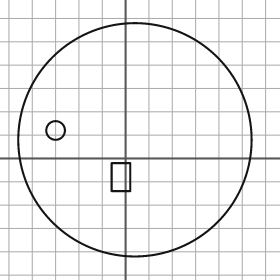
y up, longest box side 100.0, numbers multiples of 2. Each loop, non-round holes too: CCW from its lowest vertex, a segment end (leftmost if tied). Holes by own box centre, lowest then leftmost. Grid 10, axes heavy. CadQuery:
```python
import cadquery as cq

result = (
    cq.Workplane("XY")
    .moveTo(4.0, 8.0)
    .circle(50.0)
    .moveTo(-6.0, -14.0)
    .lineTo(2.0, -14.0)
    .lineTo(2.0, -2.0)
    .lineTo(-6.0, -2.0)
    .close()
    .moveTo(-30.0, 12.0)
    .circle(4.0)
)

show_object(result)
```